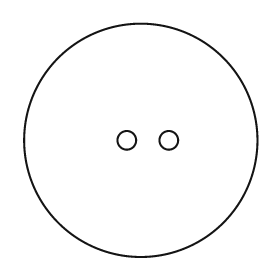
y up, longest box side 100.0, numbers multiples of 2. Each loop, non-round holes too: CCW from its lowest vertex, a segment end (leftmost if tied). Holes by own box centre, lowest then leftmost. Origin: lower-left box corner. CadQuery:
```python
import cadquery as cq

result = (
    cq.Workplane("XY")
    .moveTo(50.0, 50.0)
    .circle(50.0)
    .moveTo(44.0, 50.0)
    .circle(4.0)
    .moveTo(62.0, 50.0)
    .circle(4.0)
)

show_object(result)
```